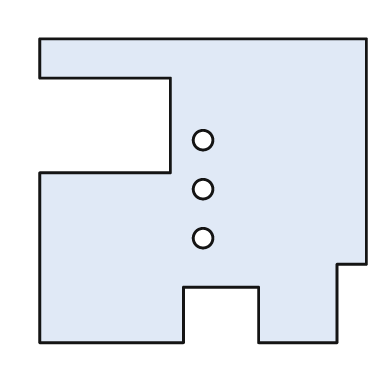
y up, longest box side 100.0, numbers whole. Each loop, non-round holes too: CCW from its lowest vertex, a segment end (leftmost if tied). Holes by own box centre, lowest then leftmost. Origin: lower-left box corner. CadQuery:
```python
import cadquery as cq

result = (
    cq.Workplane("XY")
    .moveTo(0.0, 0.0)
    .lineTo(44.0, 0.0)
    .lineTo(44.0, 17.0)
    .lineTo(67.0, 17.0)
    .lineTo(67.0, 0.0)
    .lineTo(91.0, 0.0)
    .lineTo(91.0, 24.0)
    .lineTo(100.0, 24.0)
    .lineTo(100.0, 93.0)
    .lineTo(0.0, 93.0)
    .lineTo(0.0, 81.0)
    .lineTo(40.0, 81.0)
    .lineTo(40.0, 52.0)
    .lineTo(0.0, 52.0)
    .close()
    .moveTo(50.0, 32.0)
    .circle(3.0)
    .moveTo(50.0, 47.0)
    .circle(3.0)
    .moveTo(50.0, 62.0)
    .circle(3.0)
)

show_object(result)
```